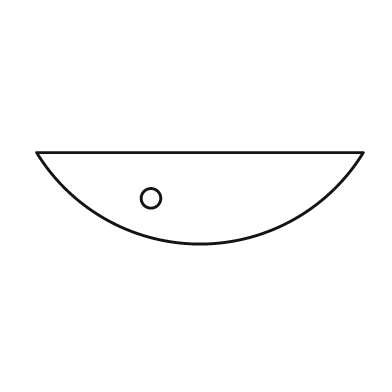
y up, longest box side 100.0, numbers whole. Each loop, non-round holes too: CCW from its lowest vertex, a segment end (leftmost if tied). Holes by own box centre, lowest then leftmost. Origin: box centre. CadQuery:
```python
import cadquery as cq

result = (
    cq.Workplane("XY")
    .moveTo(-50.0, 14.0)
    .threePointArc((0.0, -14.0), (50.0, 14.0))
    .close()
    .moveTo(-15.0, 0.0)
    .circle(3.0)
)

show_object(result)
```